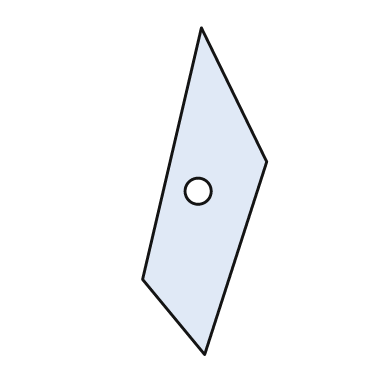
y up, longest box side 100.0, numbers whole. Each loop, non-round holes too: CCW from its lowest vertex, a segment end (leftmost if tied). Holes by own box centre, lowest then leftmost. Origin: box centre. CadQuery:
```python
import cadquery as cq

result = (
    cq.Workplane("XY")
    .moveTo(0.0, -50.0)
    .lineTo(19.0, 9.0)
    .lineTo(-1.0, 50.0)
    .lineTo(-19.0, -27.0)
    .close()
    .moveTo(-2.0, 0.0)
    .circle(4.0)
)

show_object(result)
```